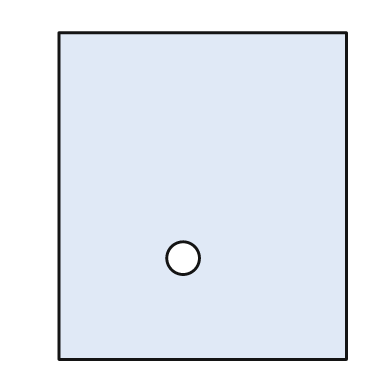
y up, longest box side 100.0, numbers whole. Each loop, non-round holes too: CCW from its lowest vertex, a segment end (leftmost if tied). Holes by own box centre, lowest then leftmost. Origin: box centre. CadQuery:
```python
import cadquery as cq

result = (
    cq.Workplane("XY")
    .moveTo(-44.0, -50.0)
    .lineTo(44.0, -50.0)
    .lineTo(44.0, 50.0)
    .lineTo(-44.0, 50.0)
    .close()
    .moveTo(-6.0, -19.0)
    .circle(5.0)
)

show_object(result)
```